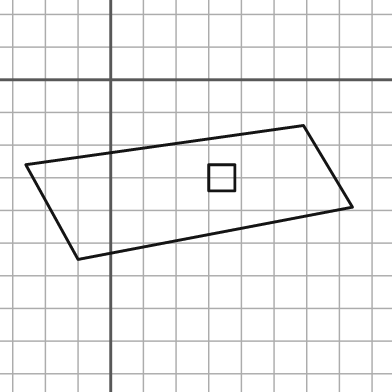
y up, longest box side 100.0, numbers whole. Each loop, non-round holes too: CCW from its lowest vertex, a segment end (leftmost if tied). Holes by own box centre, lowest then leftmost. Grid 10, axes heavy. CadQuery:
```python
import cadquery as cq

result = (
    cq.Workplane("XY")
    .moveTo(-10.0, -55.0)
    .lineTo(74.0, -39.0)
    .lineTo(59.0, -14.0)
    .lineTo(-26.0, -26.0)
    .close()
    .moveTo(30.0, -34.0)
    .lineTo(38.0, -34.0)
    .lineTo(38.0, -26.0)
    .lineTo(30.0, -26.0)
    .close()
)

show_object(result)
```